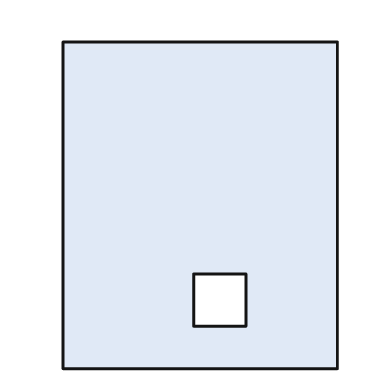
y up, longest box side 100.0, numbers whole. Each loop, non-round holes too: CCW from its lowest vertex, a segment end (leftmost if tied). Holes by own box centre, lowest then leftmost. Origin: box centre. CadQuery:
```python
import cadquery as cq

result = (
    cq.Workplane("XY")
    .moveTo(-42.0, -50.0)
    .lineTo(42.0, -50.0)
    .lineTo(42.0, 50.0)
    .lineTo(-42.0, 50.0)
    .close()
    .moveTo(-2.0, -37.0)
    .lineTo(14.0, -37.0)
    .lineTo(14.0, -21.0)
    .lineTo(-2.0, -21.0)
    .close()
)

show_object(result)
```